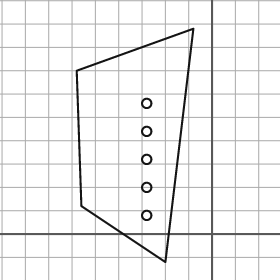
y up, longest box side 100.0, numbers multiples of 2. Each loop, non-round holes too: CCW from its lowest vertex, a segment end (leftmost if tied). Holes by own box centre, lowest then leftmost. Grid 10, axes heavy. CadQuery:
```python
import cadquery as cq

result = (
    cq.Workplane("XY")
    .moveTo(-20.0, -12.0)
    .lineTo(-8.0, 88.0)
    .lineTo(-58.0, 70.0)
    .lineTo(-56.0, 12.0)
    .close()
    .moveTo(-28.0, 8.0)
    .circle(2.0)
    .moveTo(-28.0, 20.0)
    .circle(2.0)
    .moveTo(-28.0, 32.0)
    .circle(2.0)
    .moveTo(-28.0, 44.0)
    .circle(2.0)
    .moveTo(-28.0, 56.0)
    .circle(2.0)
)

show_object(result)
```